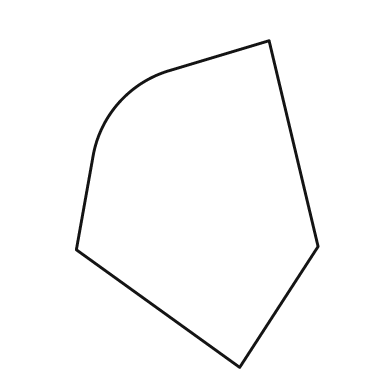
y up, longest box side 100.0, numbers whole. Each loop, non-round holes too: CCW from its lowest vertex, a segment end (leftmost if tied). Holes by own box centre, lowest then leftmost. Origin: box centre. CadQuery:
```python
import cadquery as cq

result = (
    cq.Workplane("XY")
    .moveTo(13.0, -50.0)
    .lineTo(37.0, -13.0)
    .lineTo(22.0, 50.0)
    .lineTo(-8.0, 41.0)
    .threePointArc((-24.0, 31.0), (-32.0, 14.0))
    .lineTo(-37.0, -14.0)
    .close()
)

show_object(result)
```